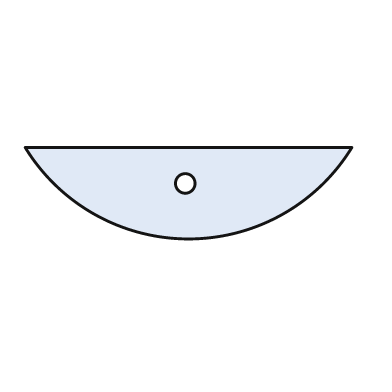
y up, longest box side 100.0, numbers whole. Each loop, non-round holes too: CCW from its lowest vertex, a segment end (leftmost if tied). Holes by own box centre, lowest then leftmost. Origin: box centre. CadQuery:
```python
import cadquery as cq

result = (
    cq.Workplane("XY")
    .moveTo(-50.0, 14.0)
    .threePointArc((0.0, -14.0), (50.0, 14.0))
    .close()
    .moveTo(-1.0, 3.0)
    .circle(3.0)
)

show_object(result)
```